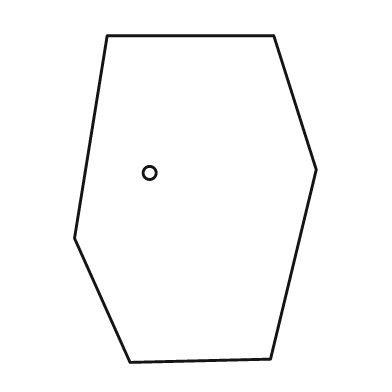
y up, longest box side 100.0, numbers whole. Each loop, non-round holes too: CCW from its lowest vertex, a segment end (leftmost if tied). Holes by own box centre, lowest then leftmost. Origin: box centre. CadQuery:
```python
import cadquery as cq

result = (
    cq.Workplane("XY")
    .moveTo(-20.0, -50.0)
    .lineTo(23.0, -49.0)
    .lineTo(37.0, 9.0)
    .lineTo(24.0, 50.0)
    .lineTo(-27.0, 50.0)
    .lineTo(-37.0, -12.0)
    .close()
    .moveTo(-14.0, 8.0)
    .circle(2.0)
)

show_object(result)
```